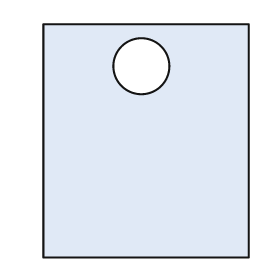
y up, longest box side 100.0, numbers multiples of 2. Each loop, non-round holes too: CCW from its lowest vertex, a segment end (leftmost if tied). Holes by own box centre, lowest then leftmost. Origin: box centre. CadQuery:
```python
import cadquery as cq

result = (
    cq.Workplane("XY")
    .moveTo(-44.0, -50.0)
    .lineTo(44.0, -50.0)
    .lineTo(44.0, 50.0)
    .lineTo(-44.0, 50.0)
    .close()
    .moveTo(-2.0, 32.0)
    .circle(12.0)
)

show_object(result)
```